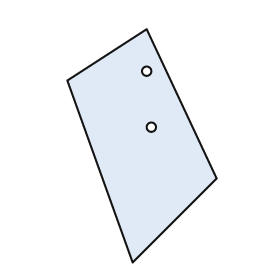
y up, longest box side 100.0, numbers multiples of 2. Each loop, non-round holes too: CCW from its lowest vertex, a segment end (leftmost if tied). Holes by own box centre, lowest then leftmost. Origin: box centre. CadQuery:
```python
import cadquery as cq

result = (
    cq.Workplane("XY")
    .moveTo(-4.0, -50.0)
    .lineTo(32.0, -14.0)
    .lineTo(2.0, 50.0)
    .lineTo(-32.0, 28.0)
    .close()
    .moveTo(4.0, 8.0)
    .circle(2.0)
    .moveTo(2.0, 32.0)
    .circle(2.0)
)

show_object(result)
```